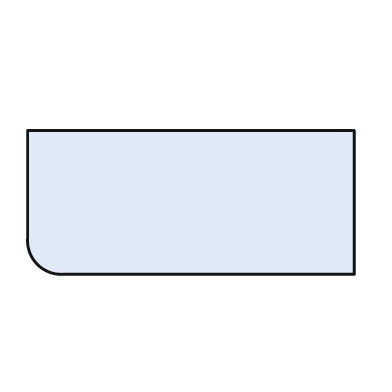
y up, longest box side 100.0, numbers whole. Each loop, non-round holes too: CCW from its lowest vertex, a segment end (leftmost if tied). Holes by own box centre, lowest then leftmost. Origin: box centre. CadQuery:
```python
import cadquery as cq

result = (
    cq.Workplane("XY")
    .moveTo(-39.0, -22.0)
    .lineTo(50.0, -22.0)
    .lineTo(50.0, 22.0)
    .lineTo(-50.0, 22.0)
    .lineTo(-50.0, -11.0)
    .threePointArc((-47.0, -19.0), (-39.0, -22.0))
    .close()
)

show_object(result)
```